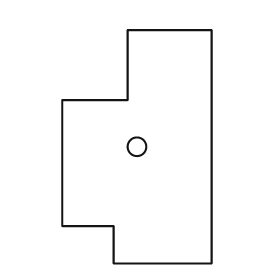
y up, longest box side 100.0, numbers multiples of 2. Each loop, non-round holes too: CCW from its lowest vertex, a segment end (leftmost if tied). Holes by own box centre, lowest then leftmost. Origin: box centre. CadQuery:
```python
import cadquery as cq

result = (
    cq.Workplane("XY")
    .moveTo(-10.0, -50.0)
    .lineTo(32.0, -50.0)
    .lineTo(32.0, 50.0)
    .lineTo(-4.0, 50.0)
    .lineTo(-4.0, 20.0)
    .lineTo(-32.0, 20.0)
    .lineTo(-32.0, -34.0)
    .lineTo(-10.0, -34.0)
    .close()
    .moveTo(0.0, 0.0)
    .circle(4.0)
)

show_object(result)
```